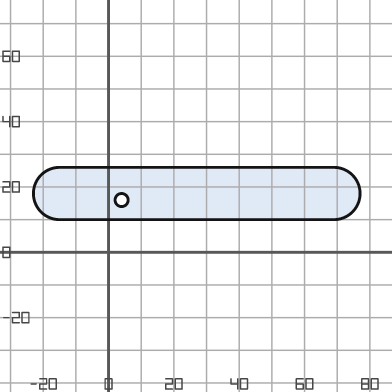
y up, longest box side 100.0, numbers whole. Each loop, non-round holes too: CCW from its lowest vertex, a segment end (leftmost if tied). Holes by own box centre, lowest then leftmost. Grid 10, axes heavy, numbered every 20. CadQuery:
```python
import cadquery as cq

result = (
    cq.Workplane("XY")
    .moveTo(-15.0, 10.0)
    .lineTo(69.0, 10.0)
    .threePointArc((77.0, 18.0), (69.0, 26.0))
    .lineTo(-15.0, 26.0)
    .threePointArc((-23.0, 18.0), (-15.0, 10.0))
    .close()
    .moveTo(4.0, 16.0)
    .circle(2.0)
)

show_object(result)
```